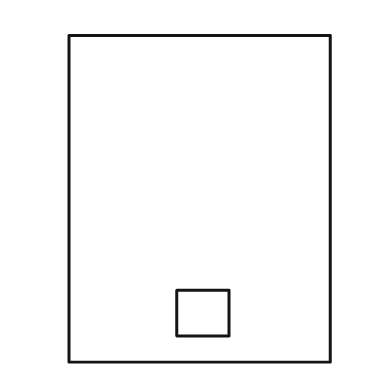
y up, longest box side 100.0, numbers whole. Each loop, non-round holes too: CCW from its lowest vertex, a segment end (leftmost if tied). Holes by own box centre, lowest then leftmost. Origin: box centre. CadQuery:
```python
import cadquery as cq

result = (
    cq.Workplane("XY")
    .moveTo(-40.0, -50.0)
    .lineTo(40.0, -50.0)
    .lineTo(40.0, 50.0)
    .lineTo(-40.0, 50.0)
    .close()
    .moveTo(-7.0, -42.0)
    .lineTo(9.0, -42.0)
    .lineTo(9.0, -28.0)
    .lineTo(-7.0, -28.0)
    .close()
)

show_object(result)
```